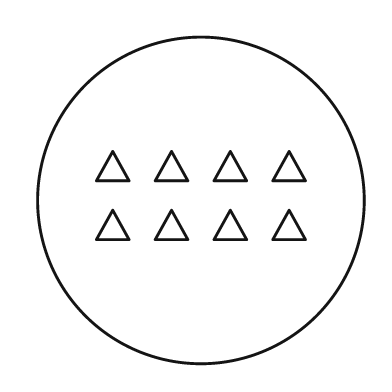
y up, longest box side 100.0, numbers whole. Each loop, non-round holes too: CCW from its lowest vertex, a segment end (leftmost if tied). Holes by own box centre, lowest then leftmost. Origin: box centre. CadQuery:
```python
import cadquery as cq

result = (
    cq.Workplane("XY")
    .moveTo(0.0, 0.0)
    .circle(50.0)
    .moveTo(-32.0, -12.0)
    .lineTo(-22.0, -12.0)
    .lineTo(-27.0, -3.0)
    .close()
    .moveTo(-14.0, -12.0)
    .lineTo(-4.0, -12.0)
    .lineTo(-9.0, -3.0)
    .close()
    .moveTo(4.0, -12.0)
    .lineTo(14.0, -12.0)
    .lineTo(9.0, -3.0)
    .close()
    .moveTo(22.0, -12.0)
    .lineTo(32.0, -12.0)
    .lineTo(27.0, -3.0)
    .close()
    .moveTo(-32.0, 6.0)
    .lineTo(-22.0, 6.0)
    .lineTo(-27.0, 15.0)
    .close()
    .moveTo(-14.0, 6.0)
    .lineTo(-4.0, 6.0)
    .lineTo(-9.0, 15.0)
    .close()
    .moveTo(4.0, 6.0)
    .lineTo(14.0, 6.0)
    .lineTo(9.0, 15.0)
    .close()
    .moveTo(22.0, 6.0)
    .lineTo(32.0, 6.0)
    .lineTo(27.0, 15.0)
    .close()
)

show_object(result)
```